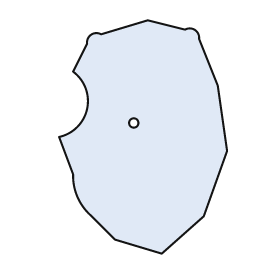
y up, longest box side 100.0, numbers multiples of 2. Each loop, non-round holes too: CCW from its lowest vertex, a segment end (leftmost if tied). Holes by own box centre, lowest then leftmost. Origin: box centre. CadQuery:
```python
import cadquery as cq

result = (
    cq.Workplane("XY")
    .moveTo(8.0, -50.0)
    .lineTo(26.0, -34.0)
    .lineTo(36.0, -6.0)
    .lineTo(32.0, 22.0)
    .lineTo(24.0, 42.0)
    .threePointArc((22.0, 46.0), (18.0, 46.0))
    .lineTo(2.0, 50.0)
    .lineTo(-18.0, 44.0)
    .threePointArc((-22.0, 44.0), (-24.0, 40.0))
    .lineTo(-30.0, 28.0)
    .threePointArc((-24.0, 12.0), (-36.0, 0.0))
    .lineTo(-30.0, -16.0)
    .threePointArc((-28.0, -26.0), (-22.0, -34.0))
    .lineTo(-12.0, -44.0)
    .close()
    .moveTo(-4.0, 6.0)
    .circle(2.0)
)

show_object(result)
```